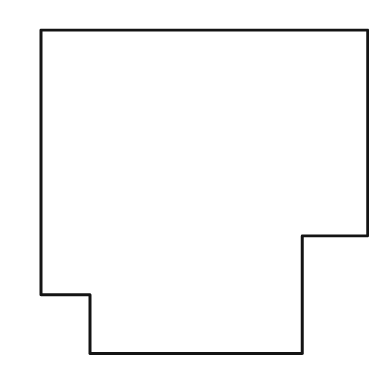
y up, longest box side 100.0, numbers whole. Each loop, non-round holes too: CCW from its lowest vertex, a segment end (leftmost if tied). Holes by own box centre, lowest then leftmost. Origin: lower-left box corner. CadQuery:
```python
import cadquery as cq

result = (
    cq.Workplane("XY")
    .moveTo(15.0, 0.0)
    .lineTo(80.0, 0.0)
    .lineTo(80.0, 36.0)
    .lineTo(100.0, 36.0)
    .lineTo(100.0, 99.0)
    .lineTo(0.0, 99.0)
    .lineTo(0.0, 18.0)
    .lineTo(15.0, 18.0)
    .close()
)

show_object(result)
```